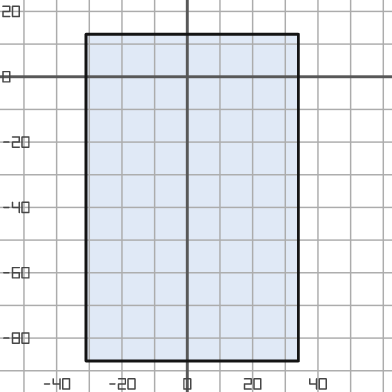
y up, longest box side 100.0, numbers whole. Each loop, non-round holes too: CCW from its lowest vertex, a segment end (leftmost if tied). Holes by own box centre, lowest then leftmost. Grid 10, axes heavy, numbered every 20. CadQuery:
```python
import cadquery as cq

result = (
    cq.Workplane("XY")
    .moveTo(-31.0, -87.0)
    .lineTo(34.0, -87.0)
    .lineTo(34.0, 13.0)
    .lineTo(-31.0, 13.0)
    .close()
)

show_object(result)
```